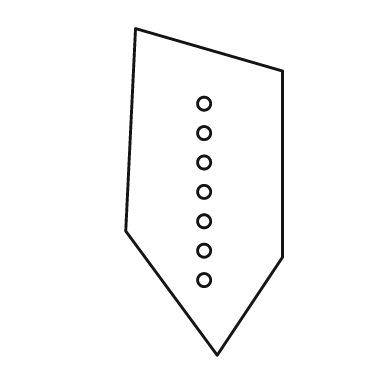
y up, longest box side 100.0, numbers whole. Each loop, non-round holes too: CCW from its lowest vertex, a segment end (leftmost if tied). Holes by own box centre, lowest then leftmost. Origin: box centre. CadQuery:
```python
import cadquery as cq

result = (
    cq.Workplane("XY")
    .moveTo(4.0, -50.0)
    .lineTo(24.0, -20.0)
    .lineTo(24.0, 37.0)
    .lineTo(-21.0, 50.0)
    .lineTo(-24.0, -12.0)
    .close()
    .moveTo(0.0, -27.0)
    .circle(2.0)
    .moveTo(0.0, -18.0)
    .circle(2.0)
    .moveTo(0.0, -9.0)
    .circle(2.0)
    .moveTo(0.0, 0.0)
    .circle(2.0)
    .moveTo(0.0, 9.0)
    .circle(2.0)
    .moveTo(0.0, 18.0)
    .circle(2.0)
    .moveTo(0.0, 27.0)
    .circle(2.0)
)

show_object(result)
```